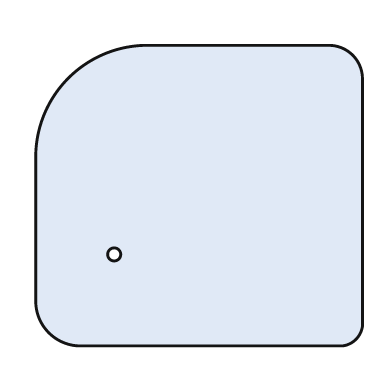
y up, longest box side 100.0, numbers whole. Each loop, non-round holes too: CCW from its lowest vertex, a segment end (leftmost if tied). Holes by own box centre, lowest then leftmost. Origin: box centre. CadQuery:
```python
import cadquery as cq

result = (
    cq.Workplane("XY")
    .moveTo(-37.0, -46.0)
    .lineTo(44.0, -46.0)
    .threePointArc((48.0, -44.0), (50.0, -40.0))
    .lineTo(50.0, 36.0)
    .threePointArc((47.0, 43.0), (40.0, 46.0))
    .lineTo(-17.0, 46.0)
    .threePointArc((-40.0, 36.0), (-50.0, 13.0))
    .lineTo(-50.0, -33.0)
    .threePointArc((-46.0, -42.0), (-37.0, -46.0))
    .close()
    .moveTo(-26.0, -18.0)
    .circle(2.0)
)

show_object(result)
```